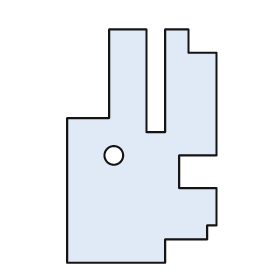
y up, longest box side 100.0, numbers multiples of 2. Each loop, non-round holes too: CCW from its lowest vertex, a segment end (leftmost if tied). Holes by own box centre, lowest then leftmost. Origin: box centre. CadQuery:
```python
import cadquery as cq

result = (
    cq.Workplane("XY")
    .moveTo(-32.0, -50.0)
    .lineTo(10.0, -50.0)
    .lineTo(10.0, -40.0)
    .lineTo(28.0, -40.0)
    .lineTo(28.0, -34.0)
    .lineTo(32.0, -34.0)
    .lineTo(32.0, -18.0)
    .lineTo(16.0, -18.0)
    .lineTo(16.0, -4.0)
    .lineTo(32.0, -4.0)
    .lineTo(32.0, 40.0)
    .lineTo(20.0, 40.0)
    .lineTo(20.0, 50.0)
    .lineTo(10.0, 50.0)
    .lineTo(10.0, 6.0)
    .lineTo(2.0, 6.0)
    .lineTo(2.0, 50.0)
    .lineTo(-14.0, 50.0)
    .lineTo(-14.0, 12.0)
    .lineTo(-32.0, 12.0)
    .close()
    .moveTo(-12.0, -4.0)
    .circle(4.0)
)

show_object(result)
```